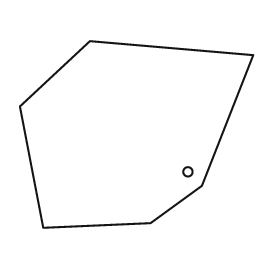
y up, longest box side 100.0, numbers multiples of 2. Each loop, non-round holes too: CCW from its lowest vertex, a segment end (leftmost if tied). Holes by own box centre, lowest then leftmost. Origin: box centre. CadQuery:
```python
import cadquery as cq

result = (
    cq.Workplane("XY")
    .moveTo(-40.0, -40.0)
    .lineTo(6.0, -38.0)
    .lineTo(28.0, -22.0)
    .lineTo(50.0, 34.0)
    .lineTo(-20.0, 40.0)
    .lineTo(-50.0, 12.0)
    .close()
    .moveTo(22.0, -16.0)
    .circle(2.0)
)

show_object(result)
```